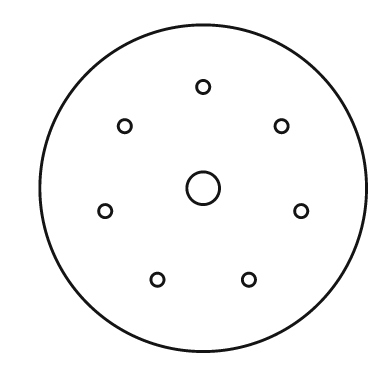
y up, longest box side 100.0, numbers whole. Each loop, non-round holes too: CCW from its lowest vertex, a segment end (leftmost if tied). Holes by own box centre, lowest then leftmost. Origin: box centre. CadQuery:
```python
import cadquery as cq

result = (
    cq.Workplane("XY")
    .moveTo(0.0, 0.0)
    .circle(50.0)
    .moveTo(-14.0, -28.0)
    .circle(2.0)
    .moveTo(14.0, -28.0)
    .circle(2.0)
    .moveTo(-30.0, -7.0)
    .circle(2.0)
    .moveTo(30.0, -7.0)
    .circle(2.0)
    .moveTo(0.0, 0.0)
    .circle(5.0)
    .moveTo(-24.0, 19.0)
    .circle(2.0)
    .moveTo(24.0, 19.0)
    .circle(2.0)
    .moveTo(0.0, 31.0)
    .circle(2.0)
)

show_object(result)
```